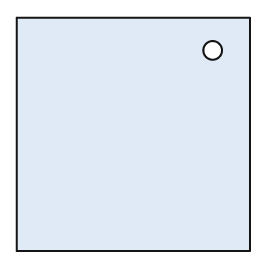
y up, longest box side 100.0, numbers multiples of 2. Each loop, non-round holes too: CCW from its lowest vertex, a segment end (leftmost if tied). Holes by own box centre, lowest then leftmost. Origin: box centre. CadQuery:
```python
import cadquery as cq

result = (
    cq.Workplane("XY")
    .moveTo(-50.0, -50.0)
    .lineTo(50.0, -50.0)
    .lineTo(50.0, 50.0)
    .lineTo(-50.0, 50.0)
    .close()
    .moveTo(34.0, 36.0)
    .circle(4.0)
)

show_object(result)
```